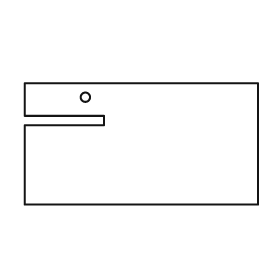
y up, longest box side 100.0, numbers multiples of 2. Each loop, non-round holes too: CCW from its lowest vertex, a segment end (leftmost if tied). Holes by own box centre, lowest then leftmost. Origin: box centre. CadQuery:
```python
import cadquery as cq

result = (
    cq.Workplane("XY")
    .moveTo(-50.0, -26.0)
    .lineTo(50.0, -26.0)
    .lineTo(50.0, 26.0)
    .lineTo(-50.0, 26.0)
    .lineTo(-50.0, 12.0)
    .lineTo(-16.0, 12.0)
    .lineTo(-16.0, 8.0)
    .lineTo(-50.0, 8.0)
    .close()
    .moveTo(-24.0, 20.0)
    .circle(2.0)
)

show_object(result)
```